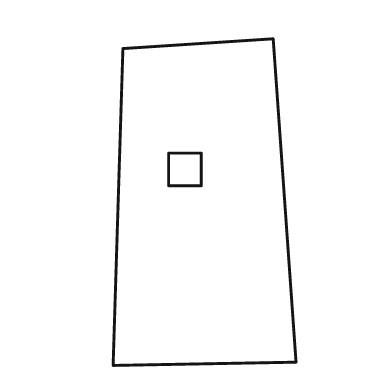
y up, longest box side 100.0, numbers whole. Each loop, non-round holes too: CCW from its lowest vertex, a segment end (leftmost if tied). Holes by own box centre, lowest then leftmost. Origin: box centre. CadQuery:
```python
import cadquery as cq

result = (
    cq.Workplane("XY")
    .moveTo(-28.0, -50.0)
    .lineTo(28.0, -49.0)
    .lineTo(21.0, 50.0)
    .lineTo(-25.0, 47.0)
    .close()
    .moveTo(-11.0, 5.0)
    .lineTo(-1.0, 5.0)
    .lineTo(-1.0, 15.0)
    .lineTo(-11.0, 15.0)
    .close()
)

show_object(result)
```